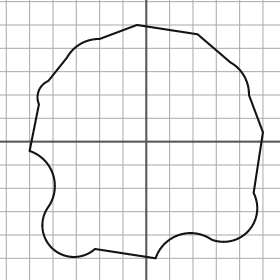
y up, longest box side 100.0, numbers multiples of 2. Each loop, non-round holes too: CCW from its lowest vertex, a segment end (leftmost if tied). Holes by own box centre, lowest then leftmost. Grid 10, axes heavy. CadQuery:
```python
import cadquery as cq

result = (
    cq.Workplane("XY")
    .moveTo(4.0, -50.0)
    .threePointArc((14.0, -40.0), (28.0, -42.0))
    .threePointArc((44.0, -38.0), (46.0, -22.0))
    .lineTo(50.0, 4.0)
    .lineTo(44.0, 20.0)
    .threePointArc((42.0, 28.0), (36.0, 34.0))
    .lineTo(22.0, 46.0)
    .lineTo(-4.0, 50.0)
    .lineTo(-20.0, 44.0)
    .threePointArc((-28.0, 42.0), (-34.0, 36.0))
    .lineTo(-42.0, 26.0)
    .threePointArc((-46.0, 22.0), (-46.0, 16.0))
    .lineTo(-50.0, -4.0)
    .threePointArc((-40.0, -14.0), (-42.0, -28.0))
    .threePointArc((-40.0, -46.0), (-22.0, -46.0))
    .close()
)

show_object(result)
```